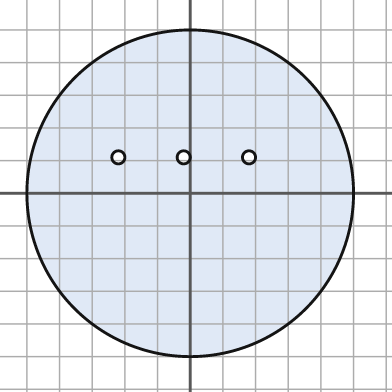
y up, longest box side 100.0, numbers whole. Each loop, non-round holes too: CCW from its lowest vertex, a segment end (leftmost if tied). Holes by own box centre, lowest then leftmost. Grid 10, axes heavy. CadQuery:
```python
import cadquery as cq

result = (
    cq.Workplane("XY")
    .moveTo(0.0, 0.0)
    .circle(50.0)
    .moveTo(-22.0, 11.0)
    .circle(2.0)
    .moveTo(-2.0, 11.0)
    .circle(2.0)
    .moveTo(18.0, 11.0)
    .circle(2.0)
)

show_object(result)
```